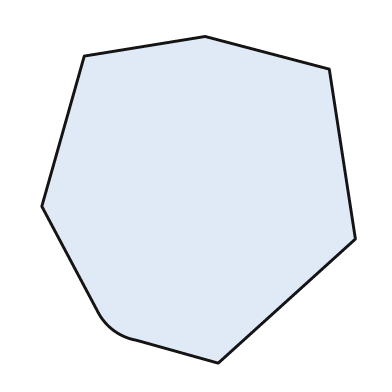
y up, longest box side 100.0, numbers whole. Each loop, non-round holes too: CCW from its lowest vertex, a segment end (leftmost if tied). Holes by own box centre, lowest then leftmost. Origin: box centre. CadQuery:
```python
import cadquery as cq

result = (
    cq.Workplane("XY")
    .moveTo(6.0, -50.0)
    .lineTo(48.0, -12.0)
    .lineTo(40.0, 40.0)
    .lineTo(2.0, 50.0)
    .lineTo(-35.0, 44.0)
    .lineTo(-48.0, -2.0)
    .lineTo(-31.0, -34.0)
    .threePointArc((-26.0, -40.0), (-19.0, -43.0))
    .close()
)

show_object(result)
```